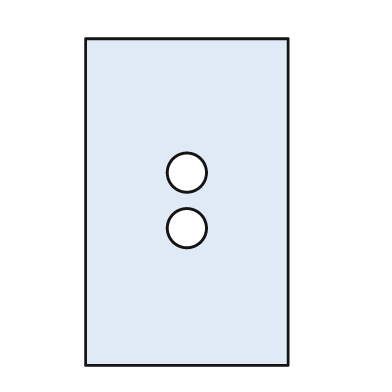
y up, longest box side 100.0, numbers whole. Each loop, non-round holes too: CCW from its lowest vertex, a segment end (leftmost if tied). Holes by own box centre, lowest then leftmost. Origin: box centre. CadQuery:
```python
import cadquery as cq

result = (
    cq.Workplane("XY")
    .moveTo(-31.0, -50.0)
    .lineTo(31.0, -50.0)
    .lineTo(31.0, 50.0)
    .lineTo(-31.0, 50.0)
    .close()
    .moveTo(0.0, -8.0)
    .circle(6.0)
    .moveTo(0.0, 9.0)
    .circle(6.0)
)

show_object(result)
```